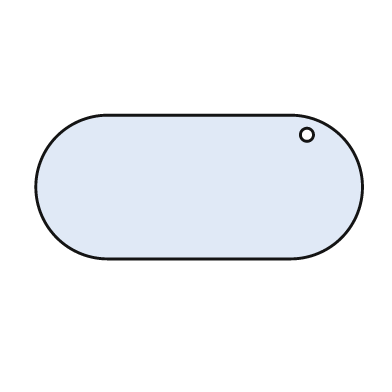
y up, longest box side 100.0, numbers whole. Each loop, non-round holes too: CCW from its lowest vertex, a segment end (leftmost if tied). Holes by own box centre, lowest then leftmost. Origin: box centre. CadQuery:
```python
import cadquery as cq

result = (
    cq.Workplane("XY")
    .moveTo(-28.0, -22.0)
    .lineTo(28.0, -22.0)
    .threePointArc((50.0, 0.0), (28.0, 22.0))
    .lineTo(-28.0, 22.0)
    .threePointArc((-50.0, 0.0), (-28.0, -22.0))
    .close()
    .moveTo(33.0, 16.0)
    .circle(2.0)
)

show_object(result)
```